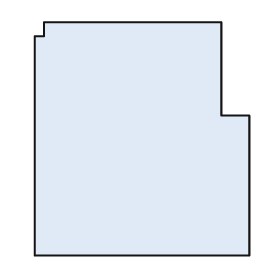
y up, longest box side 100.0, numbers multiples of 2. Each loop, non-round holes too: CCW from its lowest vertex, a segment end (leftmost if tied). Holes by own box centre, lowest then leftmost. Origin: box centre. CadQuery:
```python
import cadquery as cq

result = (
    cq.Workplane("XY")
    .moveTo(-46.0, -50.0)
    .lineTo(46.0, -50.0)
    .lineTo(46.0, 10.0)
    .lineTo(34.0, 10.0)
    .lineTo(34.0, 50.0)
    .lineTo(-42.0, 50.0)
    .lineTo(-42.0, 44.0)
    .lineTo(-46.0, 44.0)
    .close()
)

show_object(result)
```